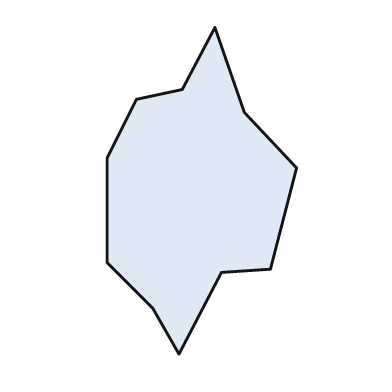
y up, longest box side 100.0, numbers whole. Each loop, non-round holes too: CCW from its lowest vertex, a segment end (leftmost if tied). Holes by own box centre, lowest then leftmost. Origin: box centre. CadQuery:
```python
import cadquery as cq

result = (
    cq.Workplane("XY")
    .moveTo(-7.0, -50.0)
    .lineTo(6.0, -25.0)
    .lineTo(21.0, -24.0)
    .lineTo(29.0, 7.0)
    .lineTo(13.0, 24.0)
    .lineTo(4.0, 50.0)
    .lineTo(-6.0, 31.0)
    .lineTo(-20.0, 28.0)
    .lineTo(-29.0, 10.0)
    .lineTo(-29.0, -22.0)
    .lineTo(-15.0, -36.0)
    .close()
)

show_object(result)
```